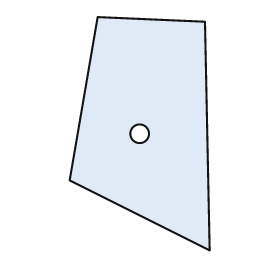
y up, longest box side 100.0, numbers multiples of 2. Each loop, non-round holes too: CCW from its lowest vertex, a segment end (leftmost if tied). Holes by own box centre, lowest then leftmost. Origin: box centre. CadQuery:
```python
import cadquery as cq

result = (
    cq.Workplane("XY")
    .moveTo(30.0, -50.0)
    .lineTo(28.0, 48.0)
    .lineTo(-18.0, 50.0)
    .lineTo(-30.0, -20.0)
    .close()
    .moveTo(0.0, 0.0)
    .circle(4.0)
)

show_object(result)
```